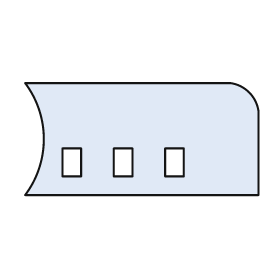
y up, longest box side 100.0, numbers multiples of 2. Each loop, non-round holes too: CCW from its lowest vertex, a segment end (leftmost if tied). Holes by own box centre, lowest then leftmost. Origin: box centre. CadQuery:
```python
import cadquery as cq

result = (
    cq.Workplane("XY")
    .moveTo(-50.0, -24.0)
    .lineTo(50.0, -24.0)
    .lineTo(50.0, 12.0)
    .threePointArc((46.0, 20.0), (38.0, 24.0))
    .lineTo(-50.0, 24.0)
    .threePointArc((-42.0, 0.0), (-50.0, -24.0))
    .close()
    .moveTo(-34.0, -16.0)
    .lineTo(-26.0, -16.0)
    .lineTo(-26.0, -4.0)
    .lineTo(-34.0, -4.0)
    .close()
    .moveTo(-12.0, -16.0)
    .lineTo(-4.0, -16.0)
    .lineTo(-4.0, -4.0)
    .lineTo(-12.0, -4.0)
    .close()
    .moveTo(10.0, -16.0)
    .lineTo(18.0, -16.0)
    .lineTo(18.0, -4.0)
    .lineTo(10.0, -4.0)
    .close()
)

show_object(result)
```